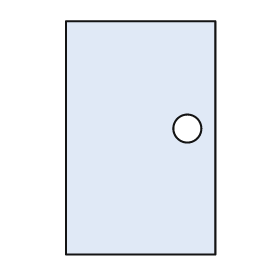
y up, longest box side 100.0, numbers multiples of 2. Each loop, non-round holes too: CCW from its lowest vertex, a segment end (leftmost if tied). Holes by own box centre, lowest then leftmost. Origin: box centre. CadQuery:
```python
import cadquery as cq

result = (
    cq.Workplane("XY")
    .moveTo(-32.0, -50.0)
    .lineTo(32.0, -50.0)
    .lineTo(32.0, 50.0)
    .lineTo(-32.0, 50.0)
    .close()
    .moveTo(20.0, 4.0)
    .circle(6.0)
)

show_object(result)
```